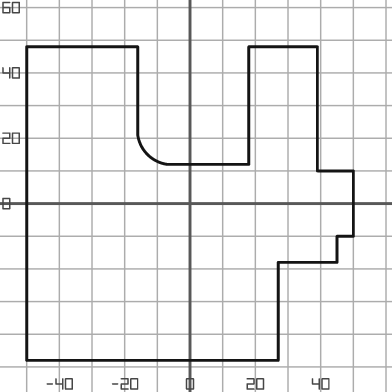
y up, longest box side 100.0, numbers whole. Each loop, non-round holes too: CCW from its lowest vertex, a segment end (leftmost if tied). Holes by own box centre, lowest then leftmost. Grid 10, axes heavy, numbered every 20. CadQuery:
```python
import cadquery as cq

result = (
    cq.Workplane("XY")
    .moveTo(-50.0, -48.0)
    .lineTo(27.0, -48.0)
    .lineTo(27.0, -18.0)
    .lineTo(45.0, -18.0)
    .lineTo(45.0, -10.0)
    .lineTo(50.0, -10.0)
    .lineTo(50.0, 10.0)
    .lineTo(39.0, 10.0)
    .lineTo(39.0, 48.0)
    .lineTo(18.0, 48.0)
    .lineTo(18.0, 12.0)
    .lineTo(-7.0, 12.0)
    .threePointArc((-13.0, 15.0), (-16.0, 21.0))
    .lineTo(-16.0, 48.0)
    .lineTo(-50.0, 48.0)
    .close()
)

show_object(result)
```